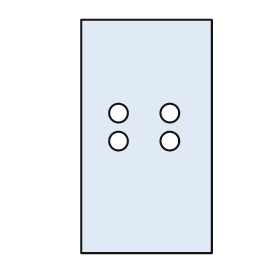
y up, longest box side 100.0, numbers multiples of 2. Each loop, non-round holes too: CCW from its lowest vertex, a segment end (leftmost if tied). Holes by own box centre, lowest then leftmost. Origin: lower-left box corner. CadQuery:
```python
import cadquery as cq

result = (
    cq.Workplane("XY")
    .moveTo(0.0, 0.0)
    .lineTo(56.0, 0.0)
    .lineTo(56.0, 100.0)
    .lineTo(0.0, 100.0)
    .close()
    .moveTo(16.0, 48.0)
    .circle(4.0)
    .moveTo(38.0, 48.0)
    .circle(4.0)
    .moveTo(16.0, 60.0)
    .circle(4.0)
    .moveTo(38.0, 60.0)
    .circle(4.0)
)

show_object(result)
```